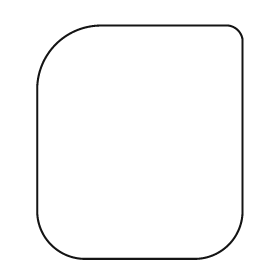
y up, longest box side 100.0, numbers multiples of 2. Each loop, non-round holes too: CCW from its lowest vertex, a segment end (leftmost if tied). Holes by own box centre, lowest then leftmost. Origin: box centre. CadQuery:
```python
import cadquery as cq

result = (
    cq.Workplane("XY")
    .moveTo(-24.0, -50.0)
    .lineTo(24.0, -50.0)
    .threePointArc((38.0, -44.0), (44.0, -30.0))
    .lineTo(44.0, 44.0)
    .threePointArc((42.0, 48.0), (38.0, 50.0))
    .lineTo(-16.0, 50.0)
    .threePointArc((-36.0, 42.0), (-44.0, 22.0))
    .lineTo(-44.0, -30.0)
    .threePointArc((-38.0, -44.0), (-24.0, -50.0))
    .close()
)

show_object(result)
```